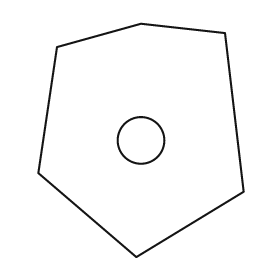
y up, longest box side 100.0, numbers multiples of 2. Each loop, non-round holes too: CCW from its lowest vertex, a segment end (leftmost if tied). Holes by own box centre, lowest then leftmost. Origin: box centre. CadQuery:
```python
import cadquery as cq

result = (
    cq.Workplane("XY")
    .moveTo(-2.0, -50.0)
    .lineTo(44.0, -22.0)
    .lineTo(36.0, 46.0)
    .lineTo(0.0, 50.0)
    .lineTo(-36.0, 40.0)
    .lineTo(-44.0, -14.0)
    .close()
    .moveTo(0.0, 0.0)
    .circle(10.0)
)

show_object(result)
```